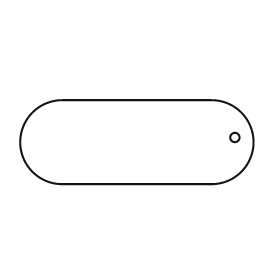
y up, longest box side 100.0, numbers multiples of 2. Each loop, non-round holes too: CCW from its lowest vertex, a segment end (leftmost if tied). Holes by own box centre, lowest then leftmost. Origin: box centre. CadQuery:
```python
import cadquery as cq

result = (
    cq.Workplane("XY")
    .moveTo(-32.0, -18.0)
    .lineTo(32.0, -18.0)
    .threePointArc((50.0, 0.0), (32.0, 18.0))
    .lineTo(-32.0, 18.0)
    .threePointArc((-50.0, 0.0), (-32.0, -18.0))
    .close()
    .moveTo(42.0, 2.0)
    .circle(2.0)
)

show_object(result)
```